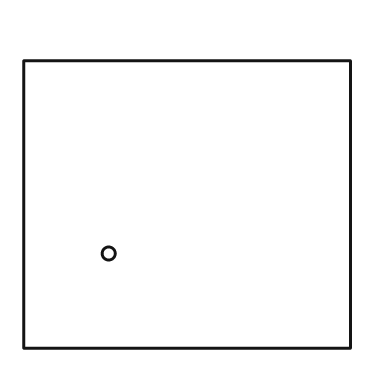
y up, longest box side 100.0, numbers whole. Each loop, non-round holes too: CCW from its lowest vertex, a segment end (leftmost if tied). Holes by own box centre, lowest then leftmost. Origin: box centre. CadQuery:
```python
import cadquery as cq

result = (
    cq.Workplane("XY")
    .moveTo(-50.0, -44.0)
    .lineTo(50.0, -44.0)
    .lineTo(50.0, 44.0)
    .lineTo(-50.0, 44.0)
    .close()
    .moveTo(-24.0, -15.0)
    .circle(2.0)
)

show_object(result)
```